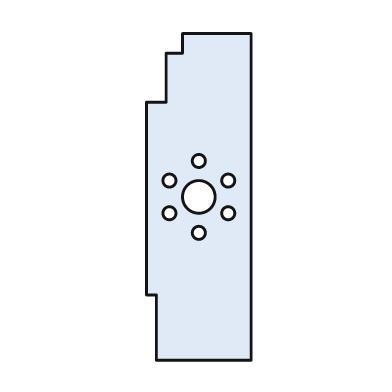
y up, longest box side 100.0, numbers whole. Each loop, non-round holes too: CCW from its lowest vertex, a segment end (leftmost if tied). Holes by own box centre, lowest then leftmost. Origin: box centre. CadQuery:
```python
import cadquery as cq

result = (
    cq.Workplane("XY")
    .moveTo(-13.0, -50.0)
    .lineTo(16.0, -50.0)
    .lineTo(16.0, 50.0)
    .lineTo(-5.0, 50.0)
    .lineTo(-5.0, 44.0)
    .lineTo(-10.0, 44.0)
    .lineTo(-10.0, 29.0)
    .lineTo(-16.0, 29.0)
    .lineTo(-16.0, -30.0)
    .lineTo(-13.0, -30.0)
    .close()
    .moveTo(0.0, -11.0)
    .circle(2.0)
    .moveTo(-9.0, -5.0)
    .circle(2.0)
    .moveTo(9.0, -5.0)
    .circle(2.0)
    .moveTo(0.0, 0.0)
    .circle(5.0)
    .moveTo(-9.0, 5.0)
    .circle(2.0)
    .moveTo(9.0, 5.0)
    .circle(2.0)
    .moveTo(0.0, 11.0)
    .circle(2.0)
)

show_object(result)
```